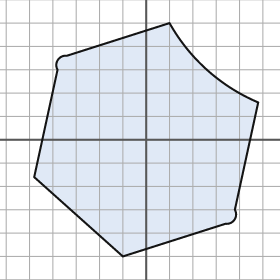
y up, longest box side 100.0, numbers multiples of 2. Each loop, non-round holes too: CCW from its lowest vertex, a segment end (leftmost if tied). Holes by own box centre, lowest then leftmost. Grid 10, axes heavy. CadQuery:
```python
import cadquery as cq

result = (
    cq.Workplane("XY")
    .moveTo(-10.0, -50.0)
    .lineTo(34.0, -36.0)
    .threePointArc((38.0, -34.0), (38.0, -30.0))
    .lineTo(48.0, 16.0)
    .threePointArc((26.0, 30.0), (10.0, 50.0))
    .lineTo(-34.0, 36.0)
    .threePointArc((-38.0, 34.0), (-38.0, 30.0))
    .lineTo(-48.0, -16.0)
    .close()
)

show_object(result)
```